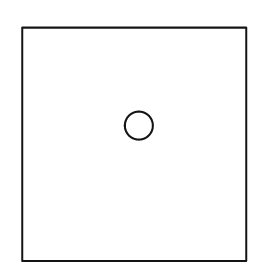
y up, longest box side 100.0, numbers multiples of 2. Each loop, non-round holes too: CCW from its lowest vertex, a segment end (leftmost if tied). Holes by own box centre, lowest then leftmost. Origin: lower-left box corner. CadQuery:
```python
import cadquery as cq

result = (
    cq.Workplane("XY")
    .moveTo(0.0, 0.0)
    .lineTo(96.0, 0.0)
    .lineTo(96.0, 100.0)
    .lineTo(0.0, 100.0)
    .close()
    .moveTo(50.0, 58.0)
    .circle(6.0)
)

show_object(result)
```